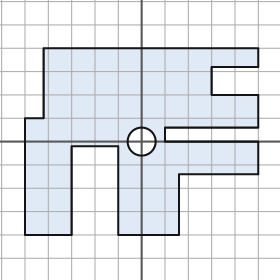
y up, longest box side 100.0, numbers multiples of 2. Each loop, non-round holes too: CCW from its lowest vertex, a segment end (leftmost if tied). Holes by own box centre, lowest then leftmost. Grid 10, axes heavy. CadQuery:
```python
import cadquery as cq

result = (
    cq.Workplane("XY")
    .moveTo(-50.0, -40.0)
    .lineTo(-30.0, -40.0)
    .lineTo(-30.0, -2.0)
    .lineTo(-10.0, -2.0)
    .lineTo(-10.0, -40.0)
    .lineTo(16.0, -40.0)
    .lineTo(16.0, -14.0)
    .lineTo(50.0, -14.0)
    .lineTo(50.0, 0.0)
    .lineTo(10.0, 0.0)
    .lineTo(10.0, 6.0)
    .lineTo(50.0, 6.0)
    .lineTo(50.0, 20.0)
    .lineTo(30.0, 20.0)
    .lineTo(30.0, 32.0)
    .lineTo(50.0, 32.0)
    .lineTo(50.0, 40.0)
    .lineTo(-42.0, 40.0)
    .lineTo(-42.0, 10.0)
    .lineTo(-50.0, 10.0)
    .close()
    .moveTo(0.0, 0.0)
    .circle(6.0)
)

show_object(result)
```